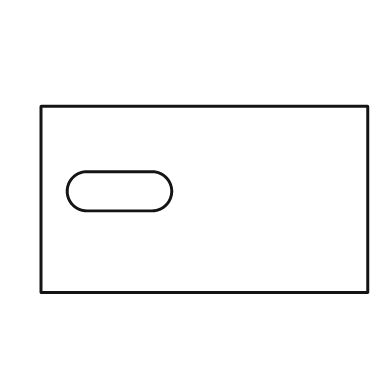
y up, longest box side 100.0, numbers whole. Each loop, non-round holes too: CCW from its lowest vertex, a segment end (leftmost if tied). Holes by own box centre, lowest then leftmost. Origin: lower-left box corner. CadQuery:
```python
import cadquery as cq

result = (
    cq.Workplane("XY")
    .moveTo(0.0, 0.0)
    .lineTo(100.0, 0.0)
    .lineTo(100.0, 57.0)
    .lineTo(0.0, 57.0)
    .close()
    .moveTo(14.0, 25.0)
    .lineTo(34.0, 25.0)
    .threePointArc((40.0, 31.0), (34.0, 37.0))
    .lineTo(14.0, 37.0)
    .threePointArc((8.0, 31.0), (14.0, 25.0))
    .close()
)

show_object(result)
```